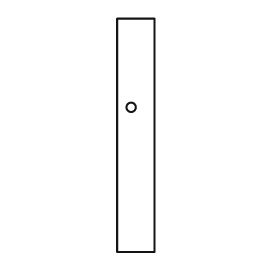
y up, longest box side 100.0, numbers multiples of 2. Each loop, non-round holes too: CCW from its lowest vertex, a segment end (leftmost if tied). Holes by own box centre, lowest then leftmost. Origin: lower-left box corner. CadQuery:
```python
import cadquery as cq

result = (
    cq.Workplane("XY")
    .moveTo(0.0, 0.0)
    .lineTo(16.0, 0.0)
    .lineTo(16.0, 100.0)
    .lineTo(0.0, 100.0)
    .close()
    .moveTo(6.0, 62.0)
    .circle(2.0)
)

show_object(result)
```